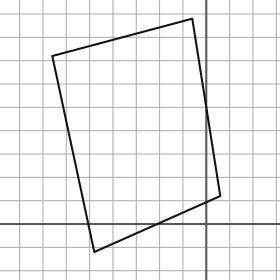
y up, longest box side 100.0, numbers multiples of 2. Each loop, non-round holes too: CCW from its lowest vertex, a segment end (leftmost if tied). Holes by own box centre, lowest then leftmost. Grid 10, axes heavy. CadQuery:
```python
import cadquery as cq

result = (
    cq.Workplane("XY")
    .moveTo(-48.0, -12.0)
    .lineTo(6.0, 12.0)
    .lineTo(-6.0, 88.0)
    .lineTo(-66.0, 72.0)
    .close()
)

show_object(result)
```